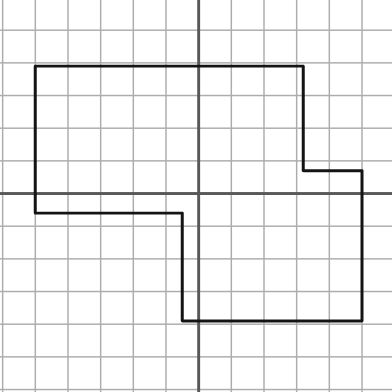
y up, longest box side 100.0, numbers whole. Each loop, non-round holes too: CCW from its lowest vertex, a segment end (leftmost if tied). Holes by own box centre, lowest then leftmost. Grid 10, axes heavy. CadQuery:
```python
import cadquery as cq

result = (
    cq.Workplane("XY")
    .moveTo(-5.0, -39.0)
    .lineTo(50.0, -39.0)
    .lineTo(50.0, 7.0)
    .lineTo(32.0, 7.0)
    .lineTo(32.0, 39.0)
    .lineTo(-50.0, 39.0)
    .lineTo(-50.0, -6.0)
    .lineTo(-5.0, -6.0)
    .close()
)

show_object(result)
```